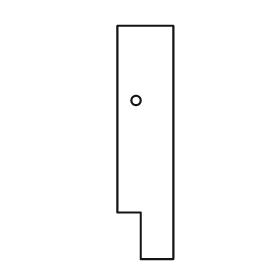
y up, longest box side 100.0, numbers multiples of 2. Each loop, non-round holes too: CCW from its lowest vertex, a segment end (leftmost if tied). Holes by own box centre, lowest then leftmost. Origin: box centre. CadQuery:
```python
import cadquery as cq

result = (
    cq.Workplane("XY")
    .moveTo(-2.0, -50.0)
    .lineTo(12.0, -50.0)
    .lineTo(12.0, 50.0)
    .lineTo(-12.0, 50.0)
    .lineTo(-12.0, -30.0)
    .lineTo(-2.0, -30.0)
    .close()
    .moveTo(-4.0, 18.0)
    .circle(2.0)
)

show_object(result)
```